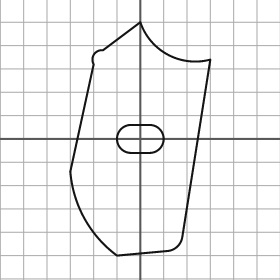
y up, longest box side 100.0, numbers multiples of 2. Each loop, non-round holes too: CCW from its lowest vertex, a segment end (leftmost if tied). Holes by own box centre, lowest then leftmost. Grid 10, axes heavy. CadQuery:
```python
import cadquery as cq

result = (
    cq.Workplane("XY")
    .moveTo(-10.0, -50.0)
    .lineTo(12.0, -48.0)
    .threePointArc((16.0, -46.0), (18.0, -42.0))
    .lineTo(30.0, 34.0)
    .threePointArc((12.0, 36.0), (0.0, 50.0))
    .lineTo(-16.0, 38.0)
    .threePointArc((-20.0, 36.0), (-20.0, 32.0))
    .lineTo(-30.0, -14.0)
    .threePointArc((-24.0, -34.0), (-10.0, -50.0))
    .close()
    .moveTo(-4.0, -6.0)
    .lineTo(4.0, -6.0)
    .threePointArc((10.0, 0.0), (4.0, 6.0))
    .lineTo(-4.0, 6.0)
    .threePointArc((-10.0, 0.0), (-4.0, -6.0))
    .close()
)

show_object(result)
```